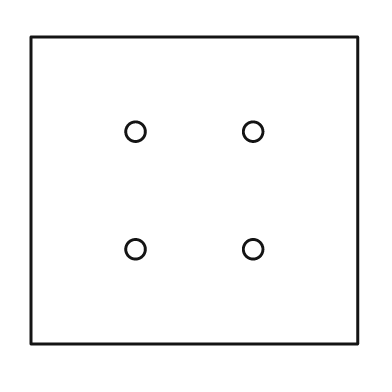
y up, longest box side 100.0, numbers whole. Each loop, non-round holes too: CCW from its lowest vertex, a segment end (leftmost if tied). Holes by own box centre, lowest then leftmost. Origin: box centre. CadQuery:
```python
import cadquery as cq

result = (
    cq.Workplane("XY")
    .moveTo(-50.0, -47.0)
    .lineTo(50.0, -47.0)
    .lineTo(50.0, 47.0)
    .lineTo(-50.0, 47.0)
    .close()
    .moveTo(-18.0, -18.0)
    .circle(3.0)
    .moveTo(18.0, -18.0)
    .circle(3.0)
    .moveTo(-18.0, 18.0)
    .circle(3.0)
    .moveTo(18.0, 18.0)
    .circle(3.0)
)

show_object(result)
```